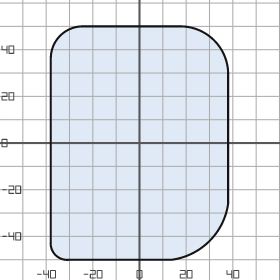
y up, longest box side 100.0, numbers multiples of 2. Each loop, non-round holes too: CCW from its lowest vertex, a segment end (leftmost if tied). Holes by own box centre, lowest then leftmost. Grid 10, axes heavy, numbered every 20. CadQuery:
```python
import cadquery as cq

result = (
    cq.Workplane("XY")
    .moveTo(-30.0, -50.0)
    .lineTo(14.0, -50.0)
    .threePointArc((30.0, -42.0), (38.0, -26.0))
    .lineTo(38.0, 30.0)
    .threePointArc((32.0, 44.0), (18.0, 50.0))
    .lineTo(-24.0, 50.0)
    .threePointArc((-34.0, 46.0), (-38.0, 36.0))
    .lineTo(-38.0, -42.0)
    .threePointArc((-36.0, -48.0), (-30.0, -50.0))
    .close()
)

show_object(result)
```